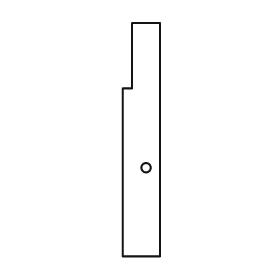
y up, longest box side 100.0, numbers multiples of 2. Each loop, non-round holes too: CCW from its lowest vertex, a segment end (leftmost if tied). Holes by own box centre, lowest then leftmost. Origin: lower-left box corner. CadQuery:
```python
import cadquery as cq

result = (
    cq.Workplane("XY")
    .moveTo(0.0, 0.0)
    .lineTo(16.0, 0.0)
    .lineTo(16.0, 100.0)
    .lineTo(4.0, 100.0)
    .lineTo(4.0, 72.0)
    .lineTo(0.0, 72.0)
    .close()
    .moveTo(10.0, 38.0)
    .circle(2.0)
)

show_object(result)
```